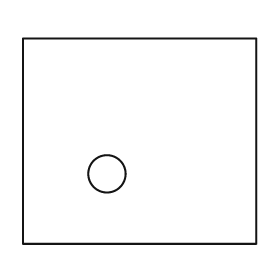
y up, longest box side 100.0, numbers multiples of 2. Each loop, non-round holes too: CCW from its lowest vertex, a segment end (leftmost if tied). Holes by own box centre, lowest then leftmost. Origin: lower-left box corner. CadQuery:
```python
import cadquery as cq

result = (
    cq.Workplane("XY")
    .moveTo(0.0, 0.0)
    .lineTo(100.0, 0.0)
    .lineTo(100.0, 88.0)
    .lineTo(0.0, 88.0)
    .close()
    .moveTo(36.0, 30.0)
    .circle(8.0)
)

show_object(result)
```